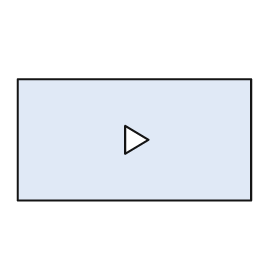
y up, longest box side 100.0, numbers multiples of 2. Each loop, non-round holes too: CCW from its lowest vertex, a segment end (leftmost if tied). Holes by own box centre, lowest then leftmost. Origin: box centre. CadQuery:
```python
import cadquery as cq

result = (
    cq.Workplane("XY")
    .moveTo(-50.0, -26.0)
    .lineTo(50.0, -26.0)
    .lineTo(50.0, 26.0)
    .lineTo(-50.0, 26.0)
    .close()
    .moveTo(-4.0, -6.0)
    .lineTo(6.0, 0.0)
    .lineTo(-4.0, 6.0)
    .close()
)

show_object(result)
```